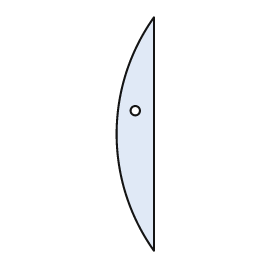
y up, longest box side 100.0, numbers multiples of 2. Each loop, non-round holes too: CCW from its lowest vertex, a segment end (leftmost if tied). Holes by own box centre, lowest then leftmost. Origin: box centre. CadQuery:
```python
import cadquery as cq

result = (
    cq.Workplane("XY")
    .moveTo(8.0, -50.0)
    .lineTo(8.0, 50.0)
    .threePointArc((-8.0, 0.0), (8.0, -50.0))
    .close()
    .moveTo(0.0, 10.0)
    .circle(2.0)
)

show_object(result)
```